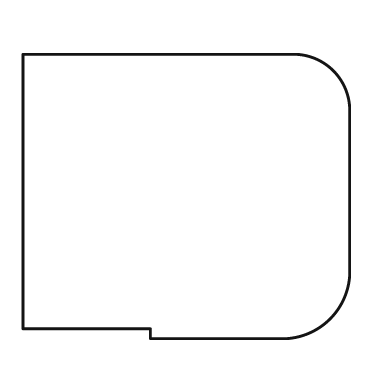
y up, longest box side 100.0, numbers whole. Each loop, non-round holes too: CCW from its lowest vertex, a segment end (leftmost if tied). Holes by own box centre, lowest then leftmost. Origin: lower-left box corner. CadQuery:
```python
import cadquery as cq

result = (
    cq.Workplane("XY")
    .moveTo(39.0, 0.0)
    .lineTo(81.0, 0.0)
    .threePointArc((94.0, 6.0), (100.0, 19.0))
    .lineTo(100.0, 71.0)
    .threePointArc((95.0, 82.0), (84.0, 87.0))
    .lineTo(0.0, 87.0)
    .lineTo(0.0, 3.0)
    .lineTo(39.0, 3.0)
    .close()
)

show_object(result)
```